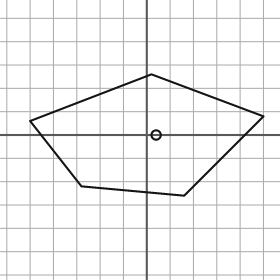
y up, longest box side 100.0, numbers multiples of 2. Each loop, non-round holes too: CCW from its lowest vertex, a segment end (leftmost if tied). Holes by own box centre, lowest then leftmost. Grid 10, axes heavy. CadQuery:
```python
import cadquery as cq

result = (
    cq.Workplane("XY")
    .moveTo(16.0, -26.0)
    .lineTo(50.0, 8.0)
    .lineTo(2.0, 26.0)
    .lineTo(-50.0, 6.0)
    .lineTo(-28.0, -22.0)
    .close()
    .moveTo(4.0, 0.0)
    .circle(2.0)
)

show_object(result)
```